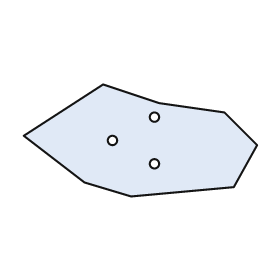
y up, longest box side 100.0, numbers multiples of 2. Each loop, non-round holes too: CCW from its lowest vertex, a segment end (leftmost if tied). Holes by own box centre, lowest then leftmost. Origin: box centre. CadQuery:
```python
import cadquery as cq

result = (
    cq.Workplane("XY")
    .moveTo(-4.0, -24.0)
    .lineTo(40.0, -20.0)
    .lineTo(50.0, -2.0)
    .lineTo(36.0, 12.0)
    .lineTo(8.0, 16.0)
    .lineTo(-16.0, 24.0)
    .lineTo(-50.0, 2.0)
    .lineTo(-24.0, -18.0)
    .close()
    .moveTo(6.0, -10.0)
    .circle(2.0)
    .moveTo(-12.0, 0.0)
    .circle(2.0)
    .moveTo(6.0, 10.0)
    .circle(2.0)
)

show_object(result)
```